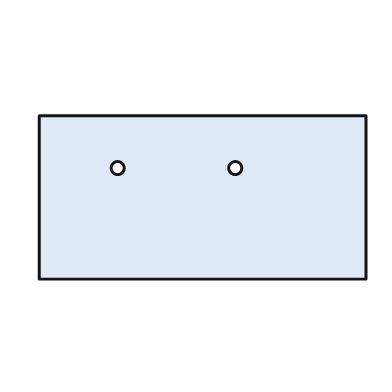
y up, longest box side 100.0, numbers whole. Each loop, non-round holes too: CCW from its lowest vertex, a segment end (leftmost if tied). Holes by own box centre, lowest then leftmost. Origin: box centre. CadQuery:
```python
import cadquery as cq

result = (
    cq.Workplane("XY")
    .moveTo(-50.0, -25.0)
    .lineTo(50.0, -25.0)
    .lineTo(50.0, 25.0)
    .lineTo(-50.0, 25.0)
    .close()
    .moveTo(-26.0, 9.0)
    .circle(2.0)
    .moveTo(10.0, 9.0)
    .circle(2.0)
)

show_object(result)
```